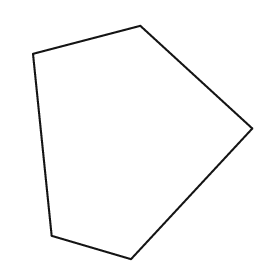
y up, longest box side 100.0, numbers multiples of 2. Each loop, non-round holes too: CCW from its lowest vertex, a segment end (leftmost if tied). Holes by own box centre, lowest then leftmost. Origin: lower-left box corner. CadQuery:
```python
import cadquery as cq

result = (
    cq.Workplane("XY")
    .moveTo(42.0, 0.0)
    .lineTo(94.0, 56.0)
    .lineTo(46.0, 100.0)
    .lineTo(0.0, 88.0)
    .lineTo(8.0, 10.0)
    .close()
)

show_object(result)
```